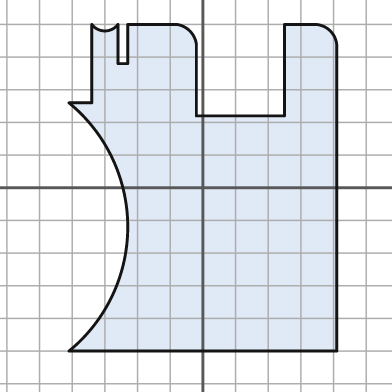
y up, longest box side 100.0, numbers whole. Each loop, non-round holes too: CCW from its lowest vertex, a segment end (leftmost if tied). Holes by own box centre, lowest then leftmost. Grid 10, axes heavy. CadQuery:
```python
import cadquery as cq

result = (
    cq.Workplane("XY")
    .moveTo(-41.0, -50.0)
    .lineTo(41.0, -50.0)
    .lineTo(41.0, 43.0)
    .threePointArc((39.0, 48.0), (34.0, 50.0))
    .lineTo(25.0, 50.0)
    .lineTo(25.0, 22.0)
    .lineTo(-2.0, 22.0)
    .lineTo(-2.0, 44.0)
    .threePointArc((-4.0, 48.0), (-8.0, 50.0))
    .lineTo(-23.0, 50.0)
    .lineTo(-23.0, 38.0)
    .lineTo(-26.0, 38.0)
    .lineTo(-26.0, 50.0)
    .threePointArc((-30.0, 48.0), (-34.0, 50.0))
    .lineTo(-34.0, 26.0)
    .lineTo(-41.0, 26.0)
    .threePointArc((-23.0, -12.0), (-41.0, -50.0))
    .close()
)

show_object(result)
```